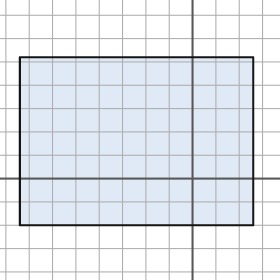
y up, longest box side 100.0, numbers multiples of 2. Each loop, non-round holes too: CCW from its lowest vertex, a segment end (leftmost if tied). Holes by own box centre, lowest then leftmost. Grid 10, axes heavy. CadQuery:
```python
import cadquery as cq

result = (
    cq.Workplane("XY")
    .moveTo(-74.0, -20.0)
    .lineTo(26.0, -20.0)
    .lineTo(26.0, 52.0)
    .lineTo(-74.0, 52.0)
    .close()
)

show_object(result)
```